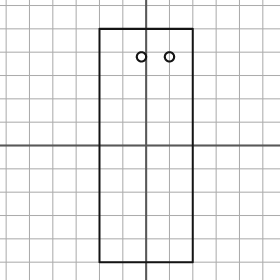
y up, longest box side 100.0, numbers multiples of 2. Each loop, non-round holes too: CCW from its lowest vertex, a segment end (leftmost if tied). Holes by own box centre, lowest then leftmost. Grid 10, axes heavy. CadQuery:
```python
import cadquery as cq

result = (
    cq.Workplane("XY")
    .moveTo(-20.0, -50.0)
    .lineTo(20.0, -50.0)
    .lineTo(20.0, 50.0)
    .lineTo(-20.0, 50.0)
    .close()
    .moveTo(-2.0, 38.0)
    .circle(2.0)
    .moveTo(10.0, 38.0)
    .circle(2.0)
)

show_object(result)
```